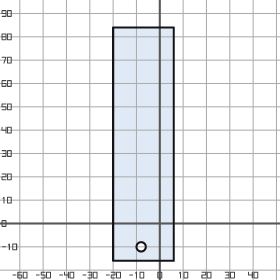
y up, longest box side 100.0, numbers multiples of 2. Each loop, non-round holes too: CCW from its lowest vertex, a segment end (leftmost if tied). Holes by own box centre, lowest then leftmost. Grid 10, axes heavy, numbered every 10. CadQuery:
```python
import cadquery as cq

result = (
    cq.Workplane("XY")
    .moveTo(-20.0, -16.0)
    .lineTo(6.0, -16.0)
    .lineTo(6.0, 84.0)
    .lineTo(-20.0, 84.0)
    .close()
    .moveTo(-8.0, -10.0)
    .circle(2.0)
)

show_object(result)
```